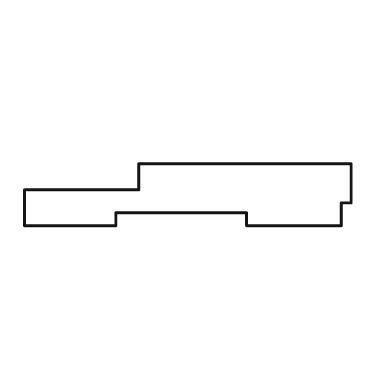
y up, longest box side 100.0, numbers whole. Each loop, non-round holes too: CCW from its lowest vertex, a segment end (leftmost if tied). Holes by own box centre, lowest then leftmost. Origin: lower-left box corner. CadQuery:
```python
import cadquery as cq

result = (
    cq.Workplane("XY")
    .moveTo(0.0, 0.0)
    .lineTo(28.0, 0.0)
    .lineTo(28.0, 4.0)
    .lineTo(68.0, 4.0)
    .lineTo(68.0, 0.0)
    .lineTo(97.0, 0.0)
    .lineTo(97.0, 7.0)
    .lineTo(100.0, 7.0)
    .lineTo(100.0, 19.0)
    .lineTo(35.0, 19.0)
    .lineTo(35.0, 11.0)
    .lineTo(0.0, 11.0)
    .close()
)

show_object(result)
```